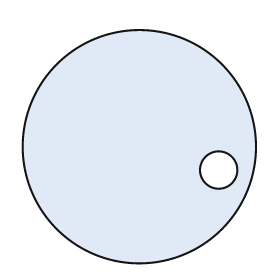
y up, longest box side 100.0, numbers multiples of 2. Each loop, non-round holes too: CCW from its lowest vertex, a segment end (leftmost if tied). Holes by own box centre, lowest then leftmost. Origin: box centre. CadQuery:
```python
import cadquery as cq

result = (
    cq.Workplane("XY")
    .moveTo(0.0, 0.0)
    .circle(50.0)
    .moveTo(34.0, -10.0)
    .circle(8.0)
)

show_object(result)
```